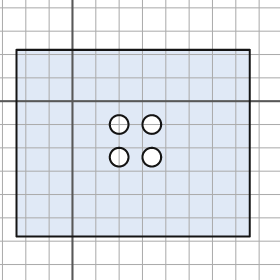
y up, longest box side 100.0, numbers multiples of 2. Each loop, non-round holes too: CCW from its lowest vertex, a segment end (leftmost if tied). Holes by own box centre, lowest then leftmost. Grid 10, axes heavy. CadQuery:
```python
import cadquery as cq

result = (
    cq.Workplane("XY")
    .moveTo(-24.0, -58.0)
    .lineTo(76.0, -58.0)
    .lineTo(76.0, 22.0)
    .lineTo(-24.0, 22.0)
    .close()
    .moveTo(20.0, -24.0)
    .circle(4.0)
    .moveTo(34.0, -24.0)
    .circle(4.0)
    .moveTo(20.0, -10.0)
    .circle(4.0)
    .moveTo(34.0, -10.0)
    .circle(4.0)
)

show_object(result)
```